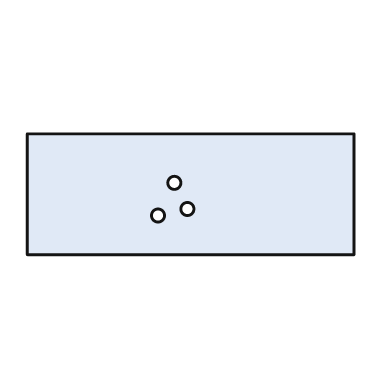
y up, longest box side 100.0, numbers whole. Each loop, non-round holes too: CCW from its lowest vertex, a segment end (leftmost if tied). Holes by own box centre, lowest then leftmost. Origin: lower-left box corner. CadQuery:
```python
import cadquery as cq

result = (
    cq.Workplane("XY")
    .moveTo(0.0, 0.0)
    .lineTo(100.0, 0.0)
    .lineTo(100.0, 37.0)
    .lineTo(0.0, 37.0)
    .close()
    .moveTo(40.0, 12.0)
    .circle(2.0)
    .moveTo(49.0, 14.0)
    .circle(2.0)
    .moveTo(45.0, 22.0)
    .circle(2.0)
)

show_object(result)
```